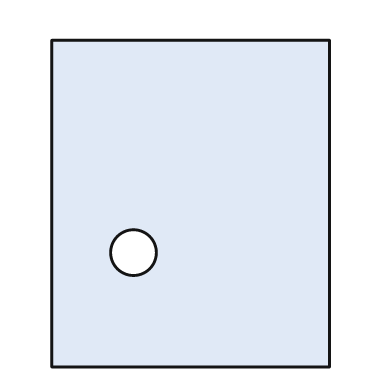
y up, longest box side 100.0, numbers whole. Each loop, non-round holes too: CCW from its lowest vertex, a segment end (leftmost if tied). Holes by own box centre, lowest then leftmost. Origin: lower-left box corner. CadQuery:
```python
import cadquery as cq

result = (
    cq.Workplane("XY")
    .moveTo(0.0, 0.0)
    .lineTo(85.0, 0.0)
    .lineTo(85.0, 100.0)
    .lineTo(0.0, 100.0)
    .close()
    .moveTo(25.0, 35.0)
    .circle(7.0)
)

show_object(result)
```